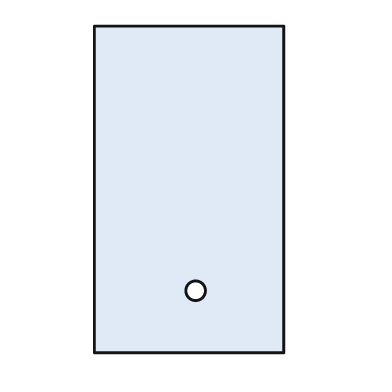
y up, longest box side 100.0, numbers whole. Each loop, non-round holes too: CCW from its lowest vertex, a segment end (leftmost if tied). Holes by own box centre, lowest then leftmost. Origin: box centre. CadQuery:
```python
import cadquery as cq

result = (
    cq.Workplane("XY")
    .moveTo(-29.0, -50.0)
    .lineTo(29.0, -50.0)
    .lineTo(29.0, 50.0)
    .lineTo(-29.0, 50.0)
    .close()
    .moveTo(2.0, -31.0)
    .circle(3.0)
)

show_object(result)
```